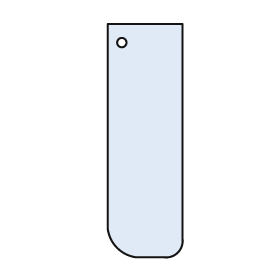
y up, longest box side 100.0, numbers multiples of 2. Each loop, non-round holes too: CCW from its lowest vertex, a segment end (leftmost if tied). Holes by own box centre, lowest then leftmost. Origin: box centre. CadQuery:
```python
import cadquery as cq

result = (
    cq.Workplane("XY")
    .moveTo(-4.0, -50.0)
    .lineTo(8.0, -50.0)
    .threePointArc((14.0, -48.0), (16.0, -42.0))
    .lineTo(16.0, 50.0)
    .lineTo(-16.0, 50.0)
    .lineTo(-16.0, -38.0)
    .threePointArc((-12.0, -46.0), (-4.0, -50.0))
    .close()
    .moveTo(-10.0, 42.0)
    .circle(2.0)
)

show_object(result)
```